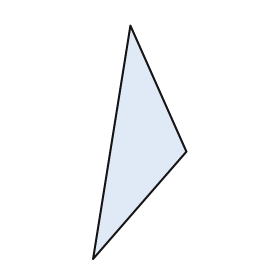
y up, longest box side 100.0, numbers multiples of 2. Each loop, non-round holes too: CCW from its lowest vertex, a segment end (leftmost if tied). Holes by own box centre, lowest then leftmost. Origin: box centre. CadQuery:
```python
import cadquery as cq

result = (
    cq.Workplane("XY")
    .moveTo(-20.0, -50.0)
    .lineTo(20.0, -4.0)
    .lineTo(-4.0, 50.0)
    .close()
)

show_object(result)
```